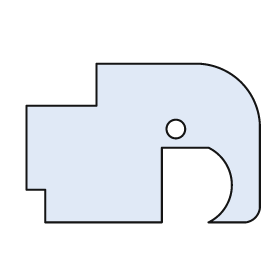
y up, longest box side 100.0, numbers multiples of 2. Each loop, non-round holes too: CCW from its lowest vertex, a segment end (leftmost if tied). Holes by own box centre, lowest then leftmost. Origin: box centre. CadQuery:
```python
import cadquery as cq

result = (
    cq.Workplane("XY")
    .moveTo(-42.0, -34.0)
    .lineTo(8.0, -34.0)
    .lineTo(8.0, -2.0)
    .lineTo(28.0, -2.0)
    .threePointArc((38.0, -18.0), (28.0, -34.0))
    .lineTo(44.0, -34.0)
    .threePointArc((48.0, -32.0), (50.0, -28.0))
    .lineTo(50.0, 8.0)
    .threePointArc((42.0, 26.0), (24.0, 34.0))
    .lineTo(-20.0, 34.0)
    .lineTo(-20.0, 16.0)
    .lineTo(-50.0, 16.0)
    .lineTo(-50.0, -20.0)
    .lineTo(-42.0, -20.0)
    .close()
    .moveTo(14.0, 6.0)
    .circle(4.0)
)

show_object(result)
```